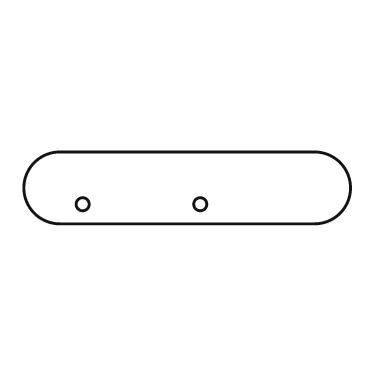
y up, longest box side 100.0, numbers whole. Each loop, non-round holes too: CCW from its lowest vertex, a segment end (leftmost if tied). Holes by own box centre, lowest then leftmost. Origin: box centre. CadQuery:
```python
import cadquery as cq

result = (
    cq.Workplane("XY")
    .moveTo(-39.0, -11.0)
    .lineTo(39.0, -11.0)
    .threePointArc((50.0, 0.0), (39.0, 11.0))
    .lineTo(-39.0, 11.0)
    .threePointArc((-50.0, 0.0), (-39.0, -11.0))
    .close()
    .moveTo(-32.0, -5.0)
    .circle(2.0)
    .moveTo(4.0, -5.0)
    .circle(2.0)
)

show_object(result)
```